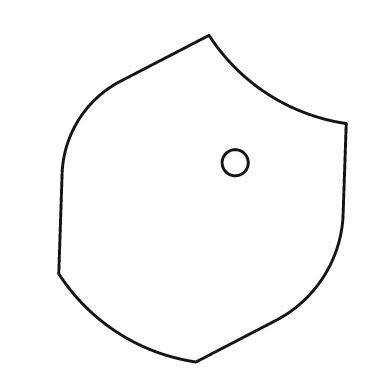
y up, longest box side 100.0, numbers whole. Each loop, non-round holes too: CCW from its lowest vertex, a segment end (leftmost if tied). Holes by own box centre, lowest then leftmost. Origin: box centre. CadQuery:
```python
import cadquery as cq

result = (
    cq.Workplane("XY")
    .moveTo(-2.0, -50.0)
    .lineTo(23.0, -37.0)
    .threePointArc((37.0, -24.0), (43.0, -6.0))
    .lineTo(44.0, 23.0)
    .threePointArc((20.0, 32.0), (2.0, 50.0))
    .lineTo(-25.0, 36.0)
    .threePointArc((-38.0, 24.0), (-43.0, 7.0))
    .lineTo(-44.0, -23.0)
    .threePointArc((-26.0, -41.0), (-2.0, -50.0))
    .close()
    .moveTo(10.0, 11.0)
    .circle(4.0)
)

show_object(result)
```